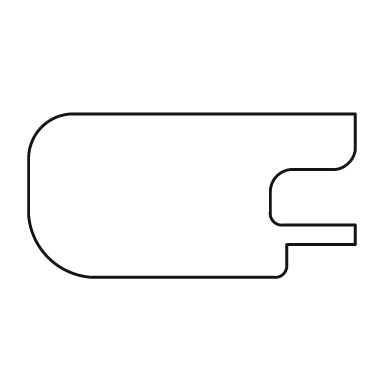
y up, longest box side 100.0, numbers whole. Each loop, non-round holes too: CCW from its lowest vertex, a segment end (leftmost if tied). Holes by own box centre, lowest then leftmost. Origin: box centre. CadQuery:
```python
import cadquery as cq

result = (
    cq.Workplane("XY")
    .moveTo(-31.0, -25.0)
    .lineTo(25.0, -25.0)
    .threePointArc((28.0, -24.0), (29.0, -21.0))
    .lineTo(29.0, -15.0)
    .lineTo(50.0, -15.0)
    .lineTo(50.0, -9.0)
    .lineTo(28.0, -9.0)
    .threePointArc((25.0, -8.0), (24.0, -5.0))
    .lineTo(24.0, 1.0)
    .threePointArc((26.0, 6.0), (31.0, 8.0))
    .lineTo(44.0, 8.0)
    .threePointArc((48.0, 10.0), (50.0, 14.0))
    .lineTo(50.0, 25.0)
    .lineTo(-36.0, 25.0)
    .threePointArc((-46.0, 21.0), (-50.0, 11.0))
    .lineTo(-50.0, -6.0)
    .threePointArc((-44.0, -19.0), (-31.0, -25.0))
    .close()
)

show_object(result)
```